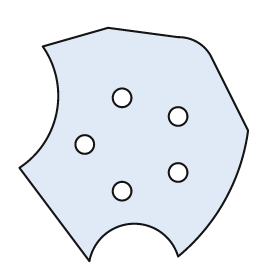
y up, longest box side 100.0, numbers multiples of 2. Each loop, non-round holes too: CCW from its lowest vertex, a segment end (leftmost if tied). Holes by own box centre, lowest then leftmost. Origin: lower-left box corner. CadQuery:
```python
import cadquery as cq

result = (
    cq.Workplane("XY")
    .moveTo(30.0, 0.0)
    .threePointArc((48.0, 16.0), (68.0, 2.0))
    .threePointArc((88.0, 26.0), (98.0, 56.0))
    .lineTo(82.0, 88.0)
    .threePointArc((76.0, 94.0), (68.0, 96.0))
    .lineTo(38.0, 100.0)
    .lineTo(10.0, 92.0)
    .threePointArc((16.0, 64.0), (0.0, 40.0))
    .close()
    .moveTo(44.0, 30.0)
    .circle(4.0)
    .moveTo(68.0, 38.0)
    .circle(4.0)
    .moveTo(28.0, 50.0)
    .circle(4.0)
    .moveTo(68.0, 62.0)
    .circle(4.0)
    .moveTo(44.0, 70.0)
    .circle(4.0)
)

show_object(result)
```